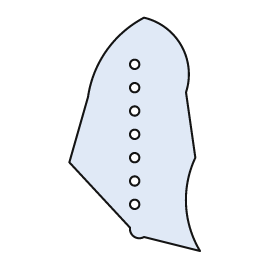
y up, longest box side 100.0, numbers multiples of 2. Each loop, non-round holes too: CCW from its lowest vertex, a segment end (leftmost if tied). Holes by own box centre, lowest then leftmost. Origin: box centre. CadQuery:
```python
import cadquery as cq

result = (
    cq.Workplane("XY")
    .moveTo(28.0, -50.0)
    .threePointArc((22.0, -30.0), (26.0, -10.0))
    .lineTo(22.0, 18.0)
    .threePointArc((20.0, 38.0), (4.0, 50.0))
    .threePointArc((-12.0, 36.0), (-20.0, 16.0))
    .lineTo(-28.0, -12.0)
    .lineTo(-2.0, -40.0)
    .threePointArc((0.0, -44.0), (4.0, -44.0))
    .close()
    .moveTo(0.0, -30.0)
    .circle(2.0)
    .moveTo(0.0, -20.0)
    .circle(2.0)
    .moveTo(0.0, -10.0)
    .circle(2.0)
    .moveTo(0.0, 0.0)
    .circle(2.0)
    .moveTo(0.0, 10.0)
    .circle(2.0)
    .moveTo(0.0, 20.0)
    .circle(2.0)
    .moveTo(0.0, 30.0)
    .circle(2.0)
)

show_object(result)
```